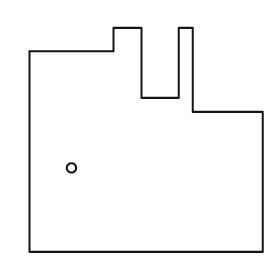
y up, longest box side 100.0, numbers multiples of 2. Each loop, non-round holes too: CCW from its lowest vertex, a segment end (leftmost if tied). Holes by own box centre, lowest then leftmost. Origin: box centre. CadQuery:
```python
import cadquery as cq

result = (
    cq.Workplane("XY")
    .moveTo(-50.0, -48.0)
    .lineTo(50.0, -48.0)
    .lineTo(50.0, 12.0)
    .lineTo(20.0, 12.0)
    .lineTo(20.0, 48.0)
    .lineTo(14.0, 48.0)
    .lineTo(14.0, 18.0)
    .lineTo(-2.0, 18.0)
    .lineTo(-2.0, 48.0)
    .lineTo(-14.0, 48.0)
    .lineTo(-14.0, 38.0)
    .lineTo(-50.0, 38.0)
    .close()
    .moveTo(-32.0, -12.0)
    .circle(2.0)
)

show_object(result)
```